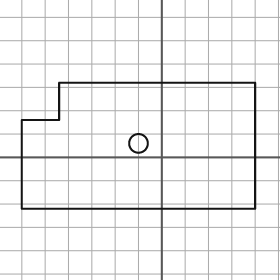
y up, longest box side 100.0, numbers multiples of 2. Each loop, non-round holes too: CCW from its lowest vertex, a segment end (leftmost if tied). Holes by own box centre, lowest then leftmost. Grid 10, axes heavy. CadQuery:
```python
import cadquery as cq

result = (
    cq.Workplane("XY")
    .moveTo(-60.0, -22.0)
    .lineTo(40.0, -22.0)
    .lineTo(40.0, 32.0)
    .lineTo(-44.0, 32.0)
    .lineTo(-44.0, 16.0)
    .lineTo(-60.0, 16.0)
    .close()
    .moveTo(-10.0, 6.0)
    .circle(4.0)
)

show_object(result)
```